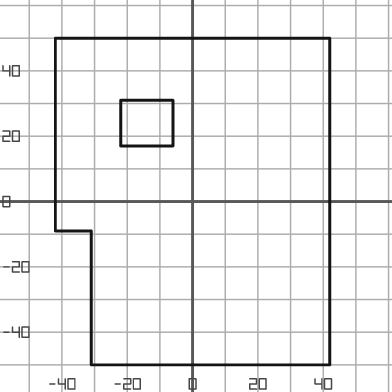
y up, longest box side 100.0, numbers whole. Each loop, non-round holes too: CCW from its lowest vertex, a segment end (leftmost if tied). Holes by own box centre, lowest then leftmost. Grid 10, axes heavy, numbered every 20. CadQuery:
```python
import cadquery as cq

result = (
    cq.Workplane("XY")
    .moveTo(-31.0, -50.0)
    .lineTo(42.0, -50.0)
    .lineTo(42.0, 50.0)
    .lineTo(-42.0, 50.0)
    .lineTo(-42.0, -9.0)
    .lineTo(-31.0, -9.0)
    .close()
    .moveTo(-22.0, 17.0)
    .lineTo(-6.0, 17.0)
    .lineTo(-6.0, 31.0)
    .lineTo(-22.0, 31.0)
    .close()
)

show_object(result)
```